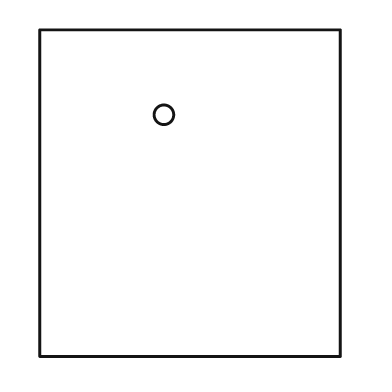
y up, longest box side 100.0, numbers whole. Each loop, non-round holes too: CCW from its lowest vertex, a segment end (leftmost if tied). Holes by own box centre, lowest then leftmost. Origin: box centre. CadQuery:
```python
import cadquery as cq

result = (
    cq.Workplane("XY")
    .moveTo(-46.0, -50.0)
    .lineTo(46.0, -50.0)
    .lineTo(46.0, 50.0)
    .lineTo(-46.0, 50.0)
    .close()
    .moveTo(-8.0, 24.0)
    .circle(3.0)
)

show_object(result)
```